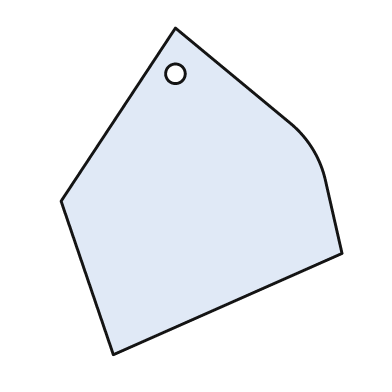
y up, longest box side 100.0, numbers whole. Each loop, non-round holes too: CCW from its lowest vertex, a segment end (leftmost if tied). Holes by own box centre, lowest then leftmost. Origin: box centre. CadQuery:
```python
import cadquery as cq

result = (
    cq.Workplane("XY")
    .moveTo(-27.0, -50.0)
    .lineTo(43.0, -19.0)
    .lineTo(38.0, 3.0)
    .threePointArc((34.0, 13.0), (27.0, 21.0))
    .lineTo(-8.0, 50.0)
    .lineTo(-43.0, -3.0)
    .close()
    .moveTo(-8.0, 36.0)
    .circle(3.0)
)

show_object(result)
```